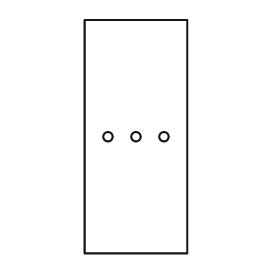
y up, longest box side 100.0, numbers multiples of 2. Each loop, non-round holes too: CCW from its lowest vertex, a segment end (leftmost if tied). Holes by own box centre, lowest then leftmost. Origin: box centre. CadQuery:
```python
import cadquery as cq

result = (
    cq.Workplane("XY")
    .moveTo(-22.0, -50.0)
    .lineTo(22.0, -50.0)
    .lineTo(22.0, 50.0)
    .lineTo(-22.0, 50.0)
    .close()
    .moveTo(-12.0, 0.0)
    .circle(2.0)
    .moveTo(0.0, 0.0)
    .circle(2.0)
    .moveTo(12.0, 0.0)
    .circle(2.0)
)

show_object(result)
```